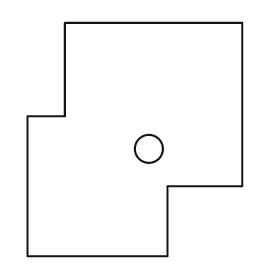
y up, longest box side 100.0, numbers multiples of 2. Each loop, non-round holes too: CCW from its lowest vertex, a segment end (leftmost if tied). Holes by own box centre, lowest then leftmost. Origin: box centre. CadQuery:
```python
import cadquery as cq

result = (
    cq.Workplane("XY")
    .moveTo(-46.0, -50.0)
    .lineTo(14.0, -50.0)
    .lineTo(14.0, -20.0)
    .lineTo(46.0, -20.0)
    .lineTo(46.0, 50.0)
    .lineTo(-30.0, 50.0)
    .lineTo(-30.0, 10.0)
    .lineTo(-46.0, 10.0)
    .close()
    .moveTo(6.0, -4.0)
    .circle(6.0)
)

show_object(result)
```